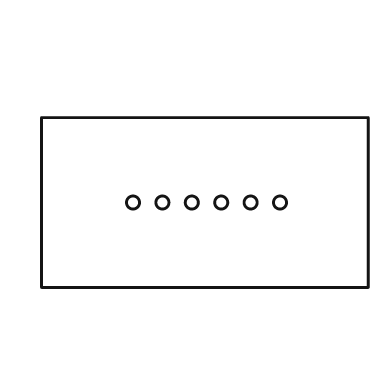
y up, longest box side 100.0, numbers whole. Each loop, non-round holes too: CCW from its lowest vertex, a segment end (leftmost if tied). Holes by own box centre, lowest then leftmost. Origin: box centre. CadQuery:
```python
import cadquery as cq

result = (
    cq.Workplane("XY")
    .moveTo(-50.0, -26.0)
    .lineTo(50.0, -26.0)
    .lineTo(50.0, 26.0)
    .lineTo(-50.0, 26.0)
    .close()
    .moveTo(-22.0, 0.0)
    .circle(2.0)
    .moveTo(-13.0, 0.0)
    .circle(2.0)
    .moveTo(-4.0, 0.0)
    .circle(2.0)
    .moveTo(5.0, 0.0)
    .circle(2.0)
    .moveTo(14.0, 0.0)
    .circle(2.0)
    .moveTo(23.0, 0.0)
    .circle(2.0)
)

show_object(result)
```